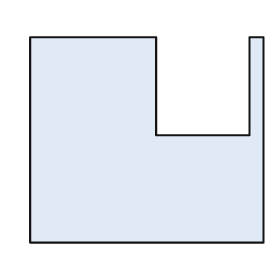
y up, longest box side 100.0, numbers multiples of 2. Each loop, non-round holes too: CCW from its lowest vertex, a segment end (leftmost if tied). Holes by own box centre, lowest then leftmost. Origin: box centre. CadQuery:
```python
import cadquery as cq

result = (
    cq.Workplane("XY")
    .moveTo(-50.0, -44.0)
    .lineTo(50.0, -44.0)
    .lineTo(50.0, 44.0)
    .lineTo(44.0, 44.0)
    .lineTo(44.0, 2.0)
    .lineTo(4.0, 2.0)
    .lineTo(4.0, 44.0)
    .lineTo(-50.0, 44.0)
    .close()
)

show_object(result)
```